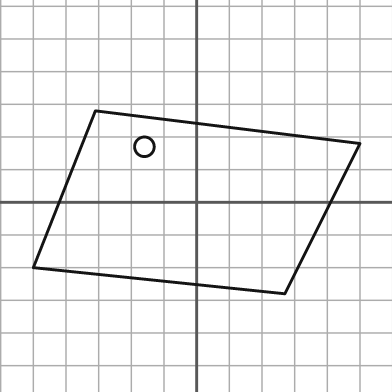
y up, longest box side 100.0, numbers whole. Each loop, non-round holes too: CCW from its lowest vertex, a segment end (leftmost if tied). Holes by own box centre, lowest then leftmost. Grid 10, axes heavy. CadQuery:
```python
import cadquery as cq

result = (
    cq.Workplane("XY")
    .moveTo(27.0, -28.0)
    .lineTo(50.0, 18.0)
    .lineTo(-31.0, 28.0)
    .lineTo(-50.0, -20.0)
    .close()
    .moveTo(-16.0, 17.0)
    .circle(3.0)
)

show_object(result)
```